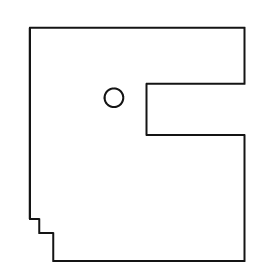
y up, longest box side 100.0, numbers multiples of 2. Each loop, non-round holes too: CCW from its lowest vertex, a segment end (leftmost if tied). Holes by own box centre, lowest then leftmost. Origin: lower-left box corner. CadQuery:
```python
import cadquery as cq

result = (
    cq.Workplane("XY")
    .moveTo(10.0, 0.0)
    .lineTo(92.0, 0.0)
    .lineTo(92.0, 54.0)
    .lineTo(50.0, 54.0)
    .lineTo(50.0, 76.0)
    .lineTo(92.0, 76.0)
    .lineTo(92.0, 100.0)
    .lineTo(0.0, 100.0)
    .lineTo(0.0, 18.0)
    .lineTo(4.0, 18.0)
    .lineTo(4.0, 12.0)
    .lineTo(10.0, 12.0)
    .close()
    .moveTo(36.0, 70.0)
    .circle(4.0)
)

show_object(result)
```